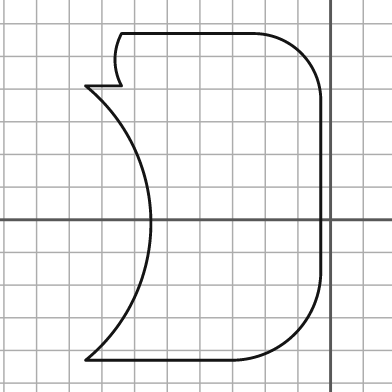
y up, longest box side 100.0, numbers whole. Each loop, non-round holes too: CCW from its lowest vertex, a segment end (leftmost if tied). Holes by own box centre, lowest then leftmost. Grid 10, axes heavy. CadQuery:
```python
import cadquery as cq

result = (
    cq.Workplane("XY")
    .moveTo(-75.0, -43.0)
    .lineTo(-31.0, -43.0)
    .threePointArc((-11.0, -35.0), (-3.0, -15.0))
    .lineTo(-3.0, 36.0)
    .threePointArc((-9.0, 51.0), (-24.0, 57.0))
    .lineTo(-64.0, 57.0)
    .threePointArc((-66.0, 49.0), (-64.0, 41.0))
    .lineTo(-75.0, 41.0)
    .threePointArc((-55.0, -1.0), (-75.0, -43.0))
    .close()
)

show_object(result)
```